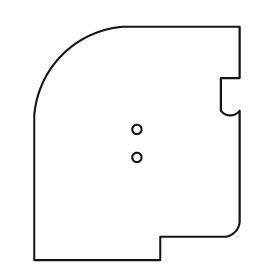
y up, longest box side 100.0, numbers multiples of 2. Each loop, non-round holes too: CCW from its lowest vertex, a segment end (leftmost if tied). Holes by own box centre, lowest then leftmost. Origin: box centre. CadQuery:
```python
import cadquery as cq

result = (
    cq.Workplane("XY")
    .moveTo(-44.0, -50.0)
    .lineTo(10.0, -50.0)
    .lineTo(10.0, -40.0)
    .lineTo(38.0, -40.0)
    .threePointArc((42.0, -38.0), (44.0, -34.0))
    .lineTo(44.0, 14.0)
    .threePointArc((40.0, 12.0), (36.0, 14.0))
    .lineTo(36.0, 28.0)
    .lineTo(44.0, 28.0)
    .lineTo(44.0, 50.0)
    .lineTo(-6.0, 50.0)
    .threePointArc((-32.0, 38.0), (-44.0, 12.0))
    .close()
    .moveTo(0.0, -6.0)
    .circle(2.0)
    .moveTo(0.0, 6.0)
    .circle(2.0)
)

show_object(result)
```